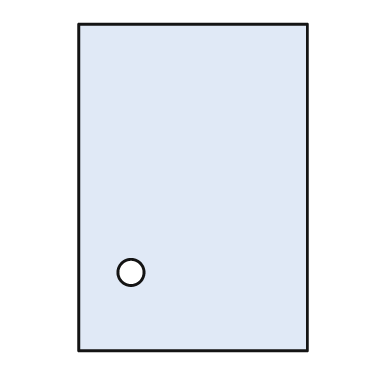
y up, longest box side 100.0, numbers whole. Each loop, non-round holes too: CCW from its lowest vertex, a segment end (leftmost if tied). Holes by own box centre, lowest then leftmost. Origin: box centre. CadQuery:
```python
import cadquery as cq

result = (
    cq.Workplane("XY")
    .moveTo(-35.0, -50.0)
    .lineTo(35.0, -50.0)
    .lineTo(35.0, 50.0)
    .lineTo(-35.0, 50.0)
    .close()
    .moveTo(-19.0, -26.0)
    .circle(4.0)
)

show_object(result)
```